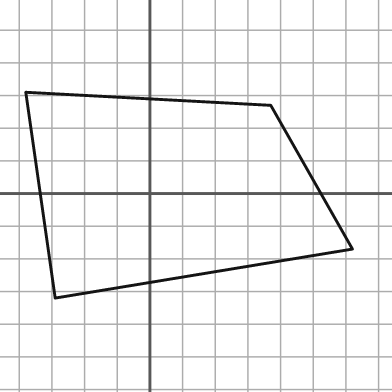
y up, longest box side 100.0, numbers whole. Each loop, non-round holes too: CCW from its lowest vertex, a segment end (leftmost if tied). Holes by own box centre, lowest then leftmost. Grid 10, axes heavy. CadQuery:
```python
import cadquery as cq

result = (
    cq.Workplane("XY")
    .moveTo(-29.0, -32.0)
    .lineTo(62.0, -17.0)
    .lineTo(37.0, 27.0)
    .lineTo(-38.0, 31.0)
    .close()
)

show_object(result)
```